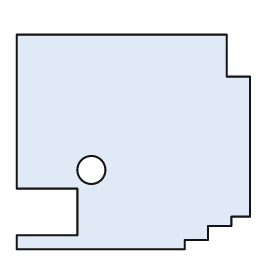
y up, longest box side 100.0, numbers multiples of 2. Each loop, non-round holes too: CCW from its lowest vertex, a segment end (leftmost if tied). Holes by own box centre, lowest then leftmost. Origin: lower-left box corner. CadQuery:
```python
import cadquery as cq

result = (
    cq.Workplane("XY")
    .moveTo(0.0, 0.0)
    .lineTo(72.0, 0.0)
    .lineTo(72.0, 4.0)
    .lineTo(82.0, 4.0)
    .lineTo(82.0, 10.0)
    .lineTo(92.0, 10.0)
    .lineTo(92.0, 14.0)
    .lineTo(100.0, 14.0)
    .lineTo(100.0, 74.0)
    .lineTo(90.0, 74.0)
    .lineTo(90.0, 92.0)
    .lineTo(0.0, 92.0)
    .lineTo(0.0, 26.0)
    .lineTo(26.0, 26.0)
    .lineTo(26.0, 6.0)
    .lineTo(0.0, 6.0)
    .close()
    .moveTo(32.0, 34.0)
    .circle(6.0)
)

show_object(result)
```